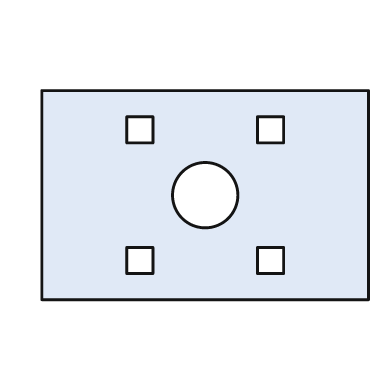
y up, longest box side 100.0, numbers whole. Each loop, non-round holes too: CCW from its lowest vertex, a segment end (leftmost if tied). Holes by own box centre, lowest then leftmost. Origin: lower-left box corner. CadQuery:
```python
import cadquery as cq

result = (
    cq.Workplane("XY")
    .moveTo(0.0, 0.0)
    .lineTo(100.0, 0.0)
    .lineTo(100.0, 64.0)
    .lineTo(0.0, 64.0)
    .close()
    .moveTo(26.0, 8.0)
    .lineTo(34.0, 8.0)
    .lineTo(34.0, 16.0)
    .lineTo(26.0, 16.0)
    .close()
    .moveTo(66.0, 8.0)
    .lineTo(74.0, 8.0)
    .lineTo(74.0, 16.0)
    .lineTo(66.0, 16.0)
    .close()
    .moveTo(50.0, 32.0)
    .circle(10.0)
    .moveTo(26.0, 48.0)
    .lineTo(34.0, 48.0)
    .lineTo(34.0, 56.0)
    .lineTo(26.0, 56.0)
    .close()
    .moveTo(66.0, 48.0)
    .lineTo(74.0, 48.0)
    .lineTo(74.0, 56.0)
    .lineTo(66.0, 56.0)
    .close()
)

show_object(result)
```